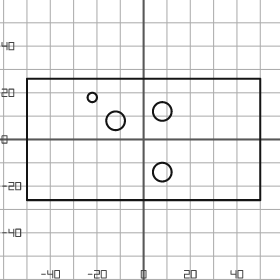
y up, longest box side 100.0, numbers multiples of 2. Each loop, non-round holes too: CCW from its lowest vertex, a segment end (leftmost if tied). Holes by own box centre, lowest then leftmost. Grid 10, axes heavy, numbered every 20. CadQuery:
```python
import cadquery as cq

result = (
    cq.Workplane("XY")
    .moveTo(-50.0, -26.0)
    .lineTo(50.0, -26.0)
    .lineTo(50.0, 26.0)
    .lineTo(-50.0, 26.0)
    .close()
    .moveTo(8.0, -14.0)
    .circle(4.0)
    .moveTo(-12.0, 8.0)
    .circle(4.0)
    .moveTo(8.0, 12.0)
    .circle(4.0)
    .moveTo(-22.0, 18.0)
    .circle(2.0)
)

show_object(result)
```